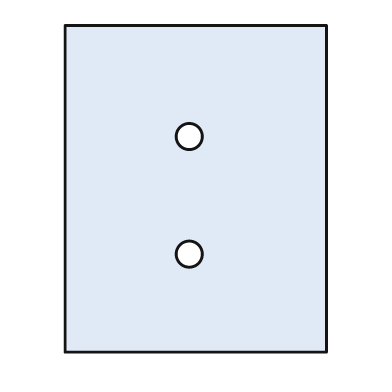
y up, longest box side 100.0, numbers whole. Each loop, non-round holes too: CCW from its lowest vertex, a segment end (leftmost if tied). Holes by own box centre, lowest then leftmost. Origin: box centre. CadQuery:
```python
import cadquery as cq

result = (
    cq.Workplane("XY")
    .moveTo(-40.0, -50.0)
    .lineTo(40.0, -50.0)
    .lineTo(40.0, 50.0)
    .lineTo(-40.0, 50.0)
    .close()
    .moveTo(-2.0, -20.0)
    .circle(4.0)
    .moveTo(-2.0, 16.0)
    .circle(4.0)
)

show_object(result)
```